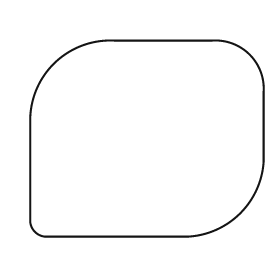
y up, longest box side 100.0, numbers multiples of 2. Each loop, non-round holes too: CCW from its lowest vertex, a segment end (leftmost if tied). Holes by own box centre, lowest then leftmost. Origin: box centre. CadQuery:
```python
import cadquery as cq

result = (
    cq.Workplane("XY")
    .moveTo(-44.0, -42.0)
    .lineTo(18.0, -42.0)
    .threePointArc((40.0, -32.0), (50.0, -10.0))
    .lineTo(50.0, 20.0)
    .threePointArc((44.0, 36.0), (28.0, 42.0))
    .lineTo(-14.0, 42.0)
    .threePointArc((-40.0, 32.0), (-50.0, 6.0))
    .lineTo(-50.0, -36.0)
    .threePointArc((-48.0, -40.0), (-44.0, -42.0))
    .close()
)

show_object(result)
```